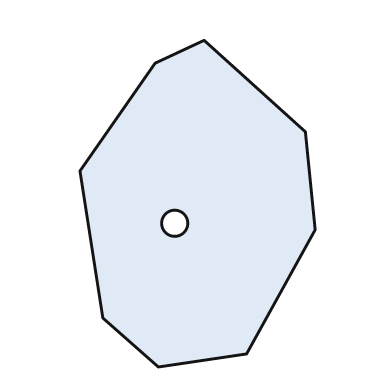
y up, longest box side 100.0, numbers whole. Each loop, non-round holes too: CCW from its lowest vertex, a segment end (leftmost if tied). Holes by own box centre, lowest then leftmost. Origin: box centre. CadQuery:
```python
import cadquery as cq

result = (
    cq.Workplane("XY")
    .moveTo(-12.0, -50.0)
    .lineTo(15.0, -46.0)
    .lineTo(36.0, -8.0)
    .lineTo(33.0, 22.0)
    .lineTo(2.0, 50.0)
    .lineTo(-13.0, 43.0)
    .lineTo(-36.0, 10.0)
    .lineTo(-29.0, -35.0)
    .close()
    .moveTo(-7.0, -6.0)
    .circle(4.0)
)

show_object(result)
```